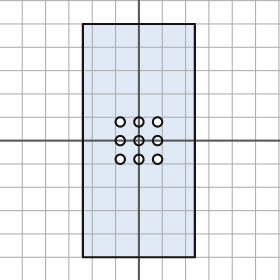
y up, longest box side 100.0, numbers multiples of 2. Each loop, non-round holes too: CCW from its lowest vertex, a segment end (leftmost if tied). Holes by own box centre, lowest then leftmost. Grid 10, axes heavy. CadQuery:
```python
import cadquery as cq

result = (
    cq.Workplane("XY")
    .moveTo(-24.0, -50.0)
    .lineTo(24.0, -50.0)
    .lineTo(24.0, 50.0)
    .lineTo(-24.0, 50.0)
    .close()
    .moveTo(-8.0, -8.0)
    .circle(2.0)
    .moveTo(0.0, -8.0)
    .circle(2.0)
    .moveTo(8.0, -8.0)
    .circle(2.0)
    .moveTo(-8.0, 0.0)
    .circle(2.0)
    .moveTo(0.0, 0.0)
    .circle(2.0)
    .moveTo(8.0, 0.0)
    .circle(2.0)
    .moveTo(-8.0, 8.0)
    .circle(2.0)
    .moveTo(0.0, 8.0)
    .circle(2.0)
    .moveTo(8.0, 8.0)
    .circle(2.0)
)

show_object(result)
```